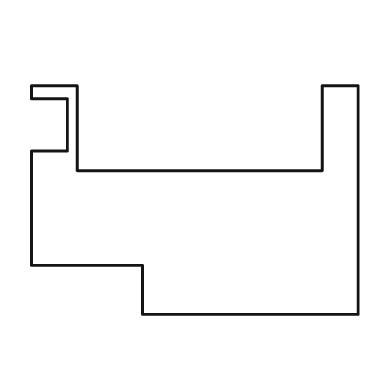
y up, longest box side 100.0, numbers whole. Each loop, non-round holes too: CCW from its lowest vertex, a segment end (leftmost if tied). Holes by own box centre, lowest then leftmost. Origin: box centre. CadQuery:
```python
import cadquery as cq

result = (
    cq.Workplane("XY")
    .moveTo(-16.0, -35.0)
    .lineTo(50.0, -35.0)
    .lineTo(50.0, 35.0)
    .lineTo(39.0, 35.0)
    .lineTo(39.0, 9.0)
    .lineTo(-36.0, 9.0)
    .lineTo(-36.0, 35.0)
    .lineTo(-50.0, 35.0)
    .lineTo(-50.0, 31.0)
    .lineTo(-39.0, 31.0)
    .lineTo(-39.0, 15.0)
    .lineTo(-50.0, 15.0)
    .lineTo(-50.0, -20.0)
    .lineTo(-16.0, -20.0)
    .close()
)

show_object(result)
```